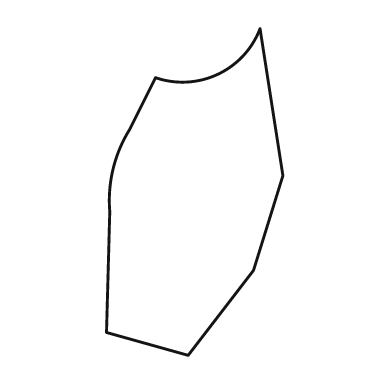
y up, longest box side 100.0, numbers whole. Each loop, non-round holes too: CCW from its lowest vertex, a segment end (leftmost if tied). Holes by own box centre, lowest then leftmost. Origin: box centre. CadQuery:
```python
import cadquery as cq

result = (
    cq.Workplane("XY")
    .moveTo(-2.0, -50.0)
    .lineTo(18.0, -24.0)
    .lineTo(27.0, 5.0)
    .lineTo(20.0, 50.0)
    .threePointArc((7.0, 36.0), (-12.0, 35.0))
    .lineTo(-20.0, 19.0)
    .threePointArc((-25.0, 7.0), (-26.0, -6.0))
    .lineTo(-27.0, -43.0)
    .close()
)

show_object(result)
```